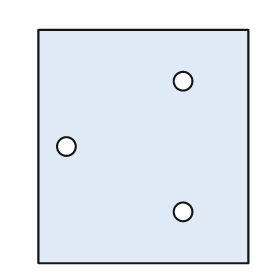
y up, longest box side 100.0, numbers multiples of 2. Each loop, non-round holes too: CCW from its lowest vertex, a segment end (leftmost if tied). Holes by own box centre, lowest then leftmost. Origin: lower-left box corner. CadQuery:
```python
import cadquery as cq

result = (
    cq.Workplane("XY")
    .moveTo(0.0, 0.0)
    .lineTo(90.0, 0.0)
    .lineTo(90.0, 100.0)
    .lineTo(0.0, 100.0)
    .close()
    .moveTo(62.0, 22.0)
    .circle(4.0)
    .moveTo(12.0, 50.0)
    .circle(4.0)
    .moveTo(62.0, 78.0)
    .circle(4.0)
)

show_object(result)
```